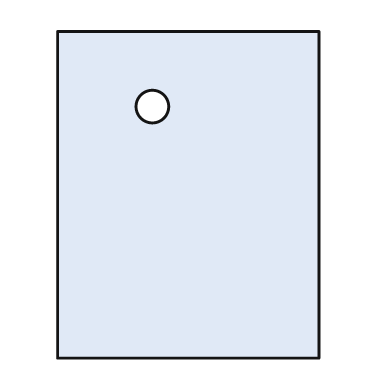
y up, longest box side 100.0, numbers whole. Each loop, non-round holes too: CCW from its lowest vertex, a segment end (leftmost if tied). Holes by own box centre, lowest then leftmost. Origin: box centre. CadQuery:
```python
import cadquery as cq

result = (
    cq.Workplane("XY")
    .moveTo(-40.0, -50.0)
    .lineTo(40.0, -50.0)
    .lineTo(40.0, 50.0)
    .lineTo(-40.0, 50.0)
    .close()
    .moveTo(-11.0, 27.0)
    .circle(5.0)
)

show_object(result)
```